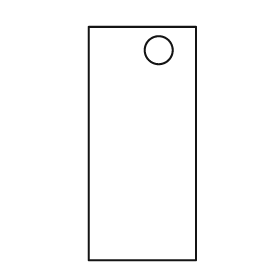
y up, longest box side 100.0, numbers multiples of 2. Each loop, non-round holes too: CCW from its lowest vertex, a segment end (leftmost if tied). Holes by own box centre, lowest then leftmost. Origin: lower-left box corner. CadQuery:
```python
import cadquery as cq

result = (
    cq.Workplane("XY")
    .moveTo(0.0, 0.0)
    .lineTo(46.0, 0.0)
    .lineTo(46.0, 100.0)
    .lineTo(0.0, 100.0)
    .close()
    .moveTo(30.0, 90.0)
    .circle(6.0)
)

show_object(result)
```